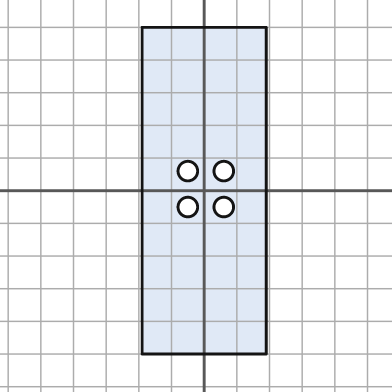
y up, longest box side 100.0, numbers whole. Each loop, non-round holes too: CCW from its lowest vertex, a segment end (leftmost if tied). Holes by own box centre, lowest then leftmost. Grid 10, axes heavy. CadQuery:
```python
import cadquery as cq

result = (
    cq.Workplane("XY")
    .moveTo(-19.0, -50.0)
    .lineTo(19.0, -50.0)
    .lineTo(19.0, 50.0)
    .lineTo(-19.0, 50.0)
    .close()
    .moveTo(-5.0, -5.0)
    .circle(3.0)
    .moveTo(6.0, -5.0)
    .circle(3.0)
    .moveTo(-5.0, 6.0)
    .circle(3.0)
    .moveTo(6.0, 6.0)
    .circle(3.0)
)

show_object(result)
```